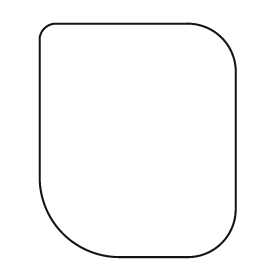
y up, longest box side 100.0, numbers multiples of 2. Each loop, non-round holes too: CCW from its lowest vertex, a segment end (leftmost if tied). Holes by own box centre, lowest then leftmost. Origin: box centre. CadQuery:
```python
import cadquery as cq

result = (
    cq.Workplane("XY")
    .moveTo(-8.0, -50.0)
    .lineTo(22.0, -50.0)
    .threePointArc((36.0, -44.0), (42.0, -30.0))
    .lineTo(42.0, 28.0)
    .threePointArc((36.0, 44.0), (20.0, 50.0))
    .lineTo(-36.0, 50.0)
    .threePointArc((-40.0, 48.0), (-42.0, 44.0))
    .lineTo(-42.0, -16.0)
    .threePointArc((-32.0, -40.0), (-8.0, -50.0))
    .close()
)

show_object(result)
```